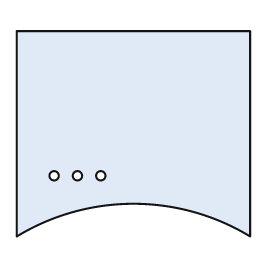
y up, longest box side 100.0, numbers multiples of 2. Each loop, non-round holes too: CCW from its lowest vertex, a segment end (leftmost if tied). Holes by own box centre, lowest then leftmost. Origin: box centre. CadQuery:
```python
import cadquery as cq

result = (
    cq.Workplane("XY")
    .moveTo(-50.0, -44.0)
    .threePointArc((0.0, -30.0), (50.0, -44.0))
    .lineTo(50.0, 44.0)
    .lineTo(-50.0, 44.0)
    .close()
    .moveTo(-34.0, -18.0)
    .circle(2.0)
    .moveTo(-24.0, -18.0)
    .circle(2.0)
    .moveTo(-14.0, -18.0)
    .circle(2.0)
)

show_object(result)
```